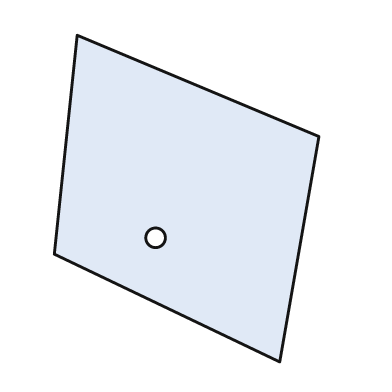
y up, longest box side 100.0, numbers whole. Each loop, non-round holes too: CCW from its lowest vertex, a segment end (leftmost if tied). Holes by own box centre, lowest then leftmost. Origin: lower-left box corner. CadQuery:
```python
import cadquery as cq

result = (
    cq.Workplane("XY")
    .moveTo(69.0, 0.0)
    .lineTo(81.0, 69.0)
    .lineTo(7.0, 100.0)
    .lineTo(0.0, 33.0)
    .close()
    .moveTo(31.0, 38.0)
    .circle(3.0)
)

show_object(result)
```